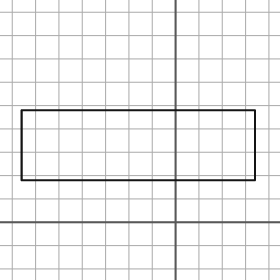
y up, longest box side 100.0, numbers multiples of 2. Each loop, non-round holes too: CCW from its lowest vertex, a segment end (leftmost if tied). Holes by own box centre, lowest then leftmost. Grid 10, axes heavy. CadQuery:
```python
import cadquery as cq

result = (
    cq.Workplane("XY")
    .moveTo(-66.0, 18.0)
    .lineTo(34.0, 18.0)
    .lineTo(34.0, 48.0)
    .lineTo(-66.0, 48.0)
    .close()
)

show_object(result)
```